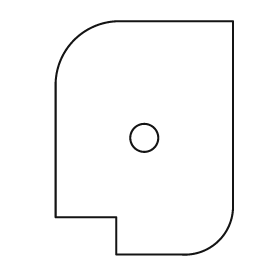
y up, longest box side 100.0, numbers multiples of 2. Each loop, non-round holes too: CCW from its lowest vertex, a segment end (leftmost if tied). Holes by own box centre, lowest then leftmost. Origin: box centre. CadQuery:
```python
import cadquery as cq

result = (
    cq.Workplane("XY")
    .moveTo(-12.0, -50.0)
    .lineTo(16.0, -50.0)
    .threePointArc((32.0, -44.0), (38.0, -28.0))
    .lineTo(38.0, 50.0)
    .lineTo(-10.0, 50.0)
    .threePointArc((-30.0, 42.0), (-38.0, 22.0))
    .lineTo(-38.0, -34.0)
    .lineTo(-12.0, -34.0)
    .close()
    .moveTo(0.0, 0.0)
    .circle(6.0)
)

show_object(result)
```